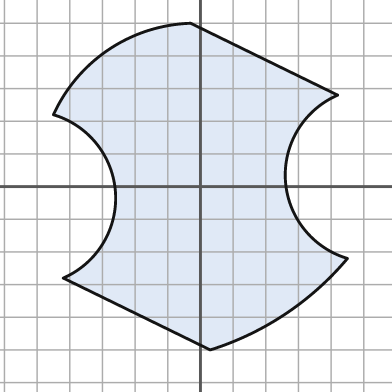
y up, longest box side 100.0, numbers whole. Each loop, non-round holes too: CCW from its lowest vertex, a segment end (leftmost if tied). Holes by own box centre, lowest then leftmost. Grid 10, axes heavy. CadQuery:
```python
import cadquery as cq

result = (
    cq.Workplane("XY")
    .moveTo(3.0, -50.0)
    .threePointArc((26.0, -39.0), (45.0, -22.0))
    .threePointArc((26.0, 2.0), (42.0, 28.0))
    .lineTo(-3.0, 50.0)
    .threePointArc((-28.0, 42.0), (-45.0, 22.0))
    .threePointArc((-26.0, -2.0), (-42.0, -28.0))
    .close()
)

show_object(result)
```